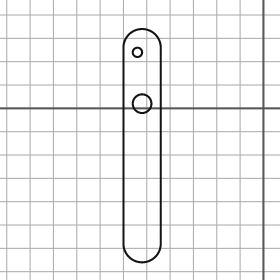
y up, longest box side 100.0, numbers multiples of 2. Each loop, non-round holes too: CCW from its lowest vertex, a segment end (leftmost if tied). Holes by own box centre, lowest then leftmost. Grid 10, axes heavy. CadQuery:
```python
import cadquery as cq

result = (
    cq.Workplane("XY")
    .moveTo(-60.0, -58.0)
    .threePointArc((-52.0, -66.0), (-44.0, -58.0))
    .lineTo(-44.0, 26.0)
    .threePointArc((-52.0, 34.0), (-60.0, 26.0))
    .close()
    .moveTo(-52.0, 2.0)
    .circle(4.0)
    .moveTo(-54.0, 24.0)
    .circle(2.0)
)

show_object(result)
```